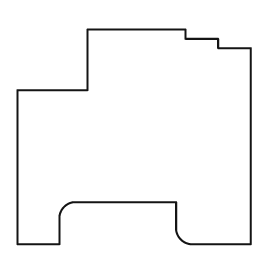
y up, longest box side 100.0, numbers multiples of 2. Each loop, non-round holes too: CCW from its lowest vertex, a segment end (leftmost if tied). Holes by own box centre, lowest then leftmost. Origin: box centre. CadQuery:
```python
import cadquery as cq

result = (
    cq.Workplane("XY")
    .moveTo(-50.0, -46.0)
    .lineTo(-32.0, -46.0)
    .lineTo(-32.0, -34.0)
    .threePointArc((-30.0, -30.0), (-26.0, -28.0))
    .lineTo(18.0, -28.0)
    .lineTo(18.0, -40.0)
    .threePointArc((20.0, -44.0), (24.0, -46.0))
    .lineTo(50.0, -46.0)
    .lineTo(50.0, 38.0)
    .lineTo(36.0, 38.0)
    .lineTo(36.0, 42.0)
    .lineTo(22.0, 42.0)
    .lineTo(22.0, 46.0)
    .lineTo(-20.0, 46.0)
    .lineTo(-20.0, 20.0)
    .lineTo(-50.0, 20.0)
    .close()
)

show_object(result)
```